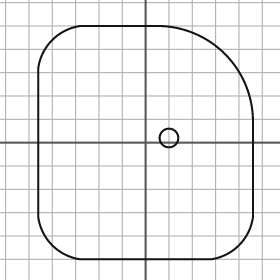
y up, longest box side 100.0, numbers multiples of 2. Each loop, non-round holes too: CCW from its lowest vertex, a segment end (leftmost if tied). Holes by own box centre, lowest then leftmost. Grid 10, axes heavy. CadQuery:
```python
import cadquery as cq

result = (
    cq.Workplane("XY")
    .moveTo(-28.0, -50.0)
    .lineTo(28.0, -50.0)
    .threePointArc((40.0, -44.0), (46.0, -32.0))
    .lineTo(46.0, 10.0)
    .threePointArc((34.0, 38.0), (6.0, 50.0))
    .lineTo(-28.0, 50.0)
    .threePointArc((-40.0, 44.0), (-46.0, 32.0))
    .lineTo(-46.0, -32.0)
    .threePointArc((-40.0, -44.0), (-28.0, -50.0))
    .close()
    .moveTo(10.0, 2.0)
    .circle(4.0)
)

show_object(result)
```